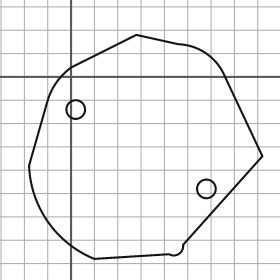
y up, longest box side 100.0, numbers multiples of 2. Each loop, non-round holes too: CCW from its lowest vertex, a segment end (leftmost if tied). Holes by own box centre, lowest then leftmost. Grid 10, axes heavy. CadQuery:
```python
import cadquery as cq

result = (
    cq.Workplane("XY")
    .moveTo(10.0, -78.0)
    .lineTo(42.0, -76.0)
    .threePointArc((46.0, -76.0), (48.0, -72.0))
    .lineTo(82.0, -34.0)
    .lineTo(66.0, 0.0)
    .threePointArc((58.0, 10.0), (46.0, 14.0))
    .lineTo(28.0, 18.0)
    .lineTo(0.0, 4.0)
    .threePointArc((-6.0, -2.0), (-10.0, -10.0))
    .lineTo(-18.0, -38.0)
    .threePointArc((-10.0, -62.0), (10.0, -78.0))
    .close()
    .moveTo(58.0, -48.0)
    .circle(4.0)
    .moveTo(2.0, -14.0)
    .circle(4.0)
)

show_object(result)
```